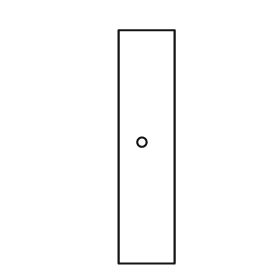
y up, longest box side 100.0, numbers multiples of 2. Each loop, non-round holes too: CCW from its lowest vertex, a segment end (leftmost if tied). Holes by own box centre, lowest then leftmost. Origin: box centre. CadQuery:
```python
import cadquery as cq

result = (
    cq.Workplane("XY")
    .moveTo(-12.0, -50.0)
    .lineTo(12.0, -50.0)
    .lineTo(12.0, 50.0)
    .lineTo(-12.0, 50.0)
    .close()
    .moveTo(-2.0, 2.0)
    .circle(2.0)
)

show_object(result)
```